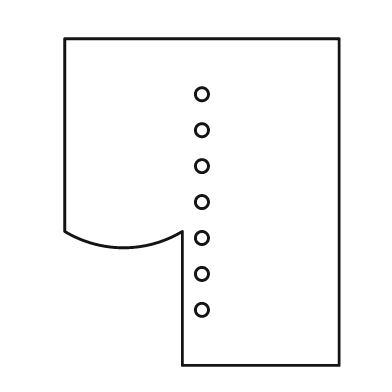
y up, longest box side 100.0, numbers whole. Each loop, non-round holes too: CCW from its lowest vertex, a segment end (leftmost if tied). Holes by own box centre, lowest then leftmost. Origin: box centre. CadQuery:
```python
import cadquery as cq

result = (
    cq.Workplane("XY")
    .moveTo(-6.0, -50.0)
    .lineTo(42.0, -50.0)
    .lineTo(42.0, 50.0)
    .lineTo(-42.0, 50.0)
    .lineTo(-42.0, -9.0)
    .threePointArc((-24.0, -14.0), (-6.0, -9.0))
    .close()
    .moveTo(0.0, -33.0)
    .circle(2.0)
    .moveTo(0.0, -22.0)
    .circle(2.0)
    .moveTo(0.0, -11.0)
    .circle(2.0)
    .moveTo(0.0, 0.0)
    .circle(2.0)
    .moveTo(0.0, 11.0)
    .circle(2.0)
    .moveTo(0.0, 22.0)
    .circle(2.0)
    .moveTo(0.0, 33.0)
    .circle(2.0)
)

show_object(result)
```